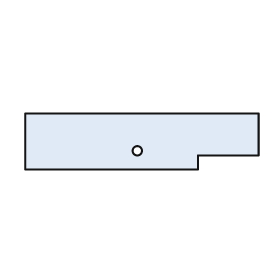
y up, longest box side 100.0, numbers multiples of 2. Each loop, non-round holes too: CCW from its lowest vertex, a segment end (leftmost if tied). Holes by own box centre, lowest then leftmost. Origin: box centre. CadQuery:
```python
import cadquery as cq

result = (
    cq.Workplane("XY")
    .moveTo(-50.0, -12.0)
    .lineTo(24.0, -12.0)
    .lineTo(24.0, -6.0)
    .lineTo(50.0, -6.0)
    .lineTo(50.0, 12.0)
    .lineTo(-50.0, 12.0)
    .close()
    .moveTo(-2.0, -4.0)
    .circle(2.0)
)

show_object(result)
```